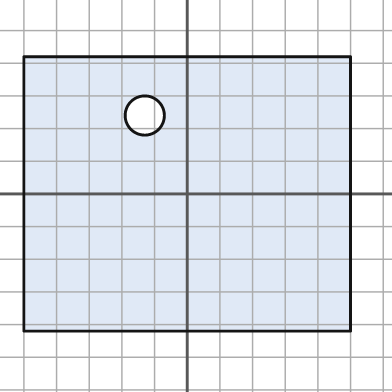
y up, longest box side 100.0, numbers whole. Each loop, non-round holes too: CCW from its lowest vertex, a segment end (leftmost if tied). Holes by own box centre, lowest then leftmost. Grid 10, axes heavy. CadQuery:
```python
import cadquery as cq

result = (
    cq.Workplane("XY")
    .moveTo(-50.0, -42.0)
    .lineTo(50.0, -42.0)
    .lineTo(50.0, 42.0)
    .lineTo(-50.0, 42.0)
    .close()
    .moveTo(-13.0, 24.0)
    .circle(6.0)
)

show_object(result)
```